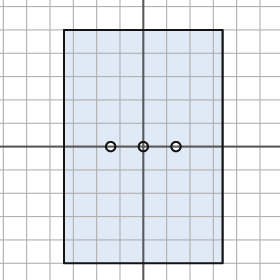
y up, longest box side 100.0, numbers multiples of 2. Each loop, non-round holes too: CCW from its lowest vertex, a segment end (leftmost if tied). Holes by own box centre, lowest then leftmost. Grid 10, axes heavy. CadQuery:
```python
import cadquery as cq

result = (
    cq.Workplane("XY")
    .moveTo(-34.0, -50.0)
    .lineTo(34.0, -50.0)
    .lineTo(34.0, 50.0)
    .lineTo(-34.0, 50.0)
    .close()
    .moveTo(-14.0, 0.0)
    .circle(2.0)
    .moveTo(0.0, 0.0)
    .circle(2.0)
    .moveTo(14.0, 0.0)
    .circle(2.0)
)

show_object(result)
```